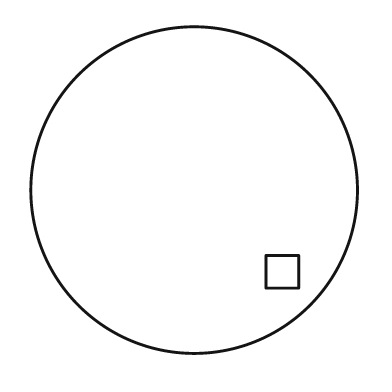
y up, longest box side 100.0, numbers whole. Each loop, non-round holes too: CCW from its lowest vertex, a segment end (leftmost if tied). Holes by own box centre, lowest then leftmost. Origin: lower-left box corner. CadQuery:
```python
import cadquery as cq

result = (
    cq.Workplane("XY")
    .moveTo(50.0, 50.0)
    .circle(50.0)
    .moveTo(72.0, 20.0)
    .lineTo(82.0, 20.0)
    .lineTo(82.0, 30.0)
    .lineTo(72.0, 30.0)
    .close()
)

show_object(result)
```